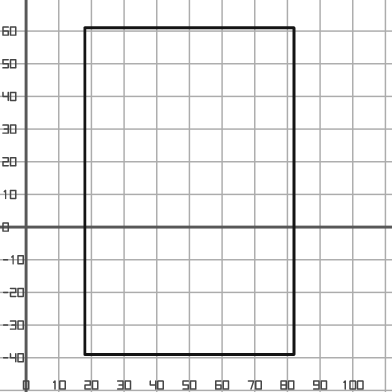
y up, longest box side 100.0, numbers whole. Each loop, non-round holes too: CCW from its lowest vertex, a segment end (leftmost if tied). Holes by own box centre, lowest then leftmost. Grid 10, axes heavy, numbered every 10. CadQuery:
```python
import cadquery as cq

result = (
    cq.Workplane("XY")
    .moveTo(18.0, -39.0)
    .lineTo(82.0, -39.0)
    .lineTo(82.0, 61.0)
    .lineTo(18.0, 61.0)
    .close()
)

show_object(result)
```